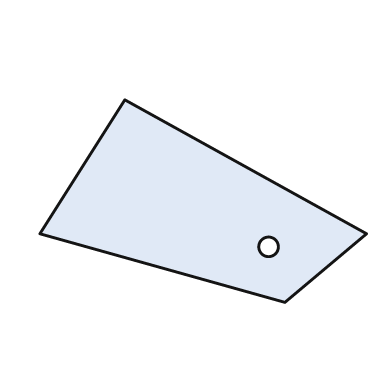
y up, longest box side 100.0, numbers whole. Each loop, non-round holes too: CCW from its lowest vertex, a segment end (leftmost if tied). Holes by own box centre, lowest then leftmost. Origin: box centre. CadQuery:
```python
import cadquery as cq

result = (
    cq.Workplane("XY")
    .moveTo(25.0, -31.0)
    .lineTo(50.0, -10.0)
    .lineTo(-24.0, 31.0)
    .lineTo(-50.0, -10.0)
    .close()
    .moveTo(20.0, -14.0)
    .circle(3.0)
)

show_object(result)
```